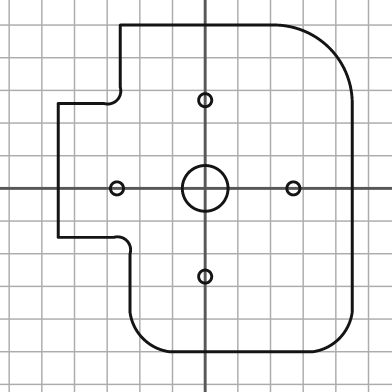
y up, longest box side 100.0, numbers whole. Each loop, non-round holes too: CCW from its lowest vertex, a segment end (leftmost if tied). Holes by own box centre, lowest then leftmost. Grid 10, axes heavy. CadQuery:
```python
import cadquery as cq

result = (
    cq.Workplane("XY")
    .moveTo(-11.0, -50.0)
    .lineTo(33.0, -50.0)
    .threePointArc((41.0, -46.0), (45.0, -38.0))
    .lineTo(45.0, 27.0)
    .threePointArc((38.0, 43.0), (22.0, 50.0))
    .lineTo(-26.0, 50.0)
    .lineTo(-26.0, 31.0)
    .threePointArc((-27.0, 27.0), (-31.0, 26.0))
    .lineTo(-45.0, 26.0)
    .lineTo(-45.0, -15.0)
    .lineTo(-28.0, -15.0)
    .threePointArc((-24.0, -16.0), (-23.0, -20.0))
    .lineTo(-23.0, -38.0)
    .threePointArc((-19.0, -46.0), (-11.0, -50.0))
    .close()
    .moveTo(0.0, -27.0)
    .circle(2.0)
    .moveTo(-27.0, 0.0)
    .circle(2.0)
    .moveTo(0.0, 0.0)
    .circle(7.0)
    .moveTo(27.0, 0.0)
    .circle(2.0)
    .moveTo(0.0, 27.0)
    .circle(2.0)
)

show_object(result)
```